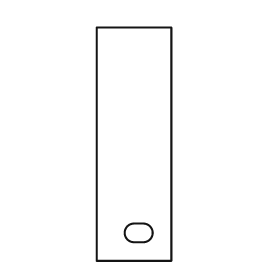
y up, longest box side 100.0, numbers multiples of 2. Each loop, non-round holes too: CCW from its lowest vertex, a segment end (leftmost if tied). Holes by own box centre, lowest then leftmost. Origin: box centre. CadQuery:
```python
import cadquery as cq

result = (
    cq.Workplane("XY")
    .moveTo(-16.0, -50.0)
    .lineTo(16.0, -50.0)
    .lineTo(16.0, 50.0)
    .lineTo(-16.0, 50.0)
    .close()
    .moveTo(0.0, -42.0)
    .lineTo(4.0, -42.0)
    .threePointArc((8.0, -38.0), (4.0, -34.0))
    .lineTo(0.0, -34.0)
    .threePointArc((-4.0, -38.0), (0.0, -42.0))
    .close()
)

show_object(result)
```